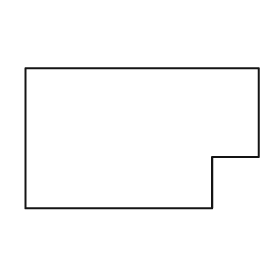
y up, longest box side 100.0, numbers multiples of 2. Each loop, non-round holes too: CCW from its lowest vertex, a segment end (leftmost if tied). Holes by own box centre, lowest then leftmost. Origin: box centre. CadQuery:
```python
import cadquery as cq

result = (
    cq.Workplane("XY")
    .moveTo(-50.0, -30.0)
    .lineTo(30.0, -30.0)
    .lineTo(30.0, -8.0)
    .lineTo(50.0, -8.0)
    .lineTo(50.0, 30.0)
    .lineTo(-50.0, 30.0)
    .close()
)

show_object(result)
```